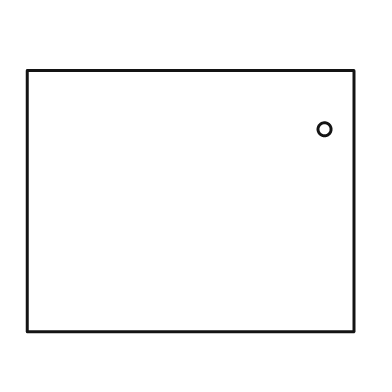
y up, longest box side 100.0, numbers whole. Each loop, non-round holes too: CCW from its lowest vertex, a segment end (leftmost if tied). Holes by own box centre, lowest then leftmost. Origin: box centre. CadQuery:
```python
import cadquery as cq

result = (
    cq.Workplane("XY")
    .moveTo(-50.0, -40.0)
    .lineTo(50.0, -40.0)
    .lineTo(50.0, 40.0)
    .lineTo(-50.0, 40.0)
    .close()
    .moveTo(41.0, 22.0)
    .circle(2.0)
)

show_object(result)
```